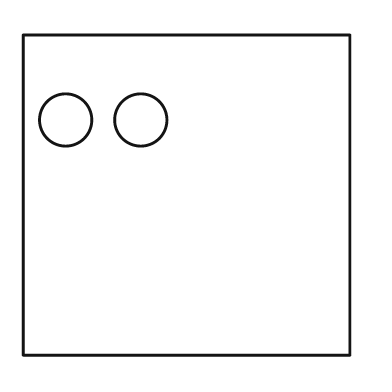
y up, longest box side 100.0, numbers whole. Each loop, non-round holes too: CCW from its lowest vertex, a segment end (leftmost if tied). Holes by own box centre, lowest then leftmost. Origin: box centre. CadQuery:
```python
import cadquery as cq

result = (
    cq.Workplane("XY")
    .moveTo(-50.0, -49.0)
    .lineTo(50.0, -49.0)
    .lineTo(50.0, 49.0)
    .lineTo(-50.0, 49.0)
    .close()
    .moveTo(-37.0, 23.0)
    .circle(8.0)
    .moveTo(-14.0, 23.0)
    .circle(8.0)
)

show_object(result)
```